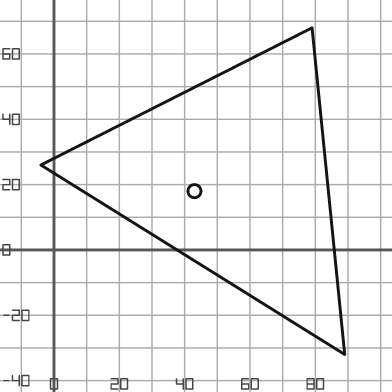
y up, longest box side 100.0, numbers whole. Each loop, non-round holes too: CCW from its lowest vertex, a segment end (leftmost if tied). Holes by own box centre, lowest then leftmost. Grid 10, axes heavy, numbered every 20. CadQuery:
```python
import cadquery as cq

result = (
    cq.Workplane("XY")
    .moveTo(89.0, -32.0)
    .lineTo(79.0, 68.0)
    .lineTo(-4.0, 26.0)
    .close()
    .moveTo(43.0, 18.0)
    .circle(2.0)
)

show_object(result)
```